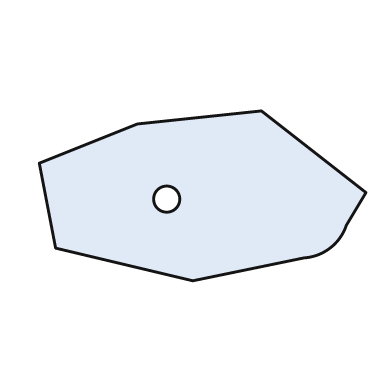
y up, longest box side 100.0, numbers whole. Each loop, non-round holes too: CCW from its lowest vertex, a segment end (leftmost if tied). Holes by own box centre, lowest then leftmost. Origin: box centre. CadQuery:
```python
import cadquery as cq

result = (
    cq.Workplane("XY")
    .moveTo(-3.0, -26.0)
    .lineTo(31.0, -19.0)
    .threePointArc((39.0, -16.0), (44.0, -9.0))
    .lineTo(50.0, 1.0)
    .lineTo(18.0, 26.0)
    .lineTo(-20.0, 22.0)
    .lineTo(-50.0, 10.0)
    .lineTo(-45.0, -16.0)
    .close()
    .moveTo(-11.0, -1.0)
    .circle(4.0)
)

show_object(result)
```